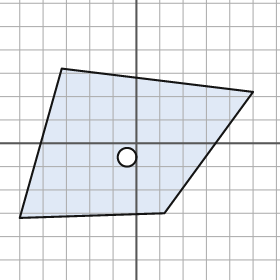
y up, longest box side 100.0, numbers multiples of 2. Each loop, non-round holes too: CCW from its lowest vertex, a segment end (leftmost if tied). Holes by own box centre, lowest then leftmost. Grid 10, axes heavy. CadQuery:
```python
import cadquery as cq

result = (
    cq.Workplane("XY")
    .moveTo(-50.0, -32.0)
    .lineTo(12.0, -30.0)
    .lineTo(50.0, 22.0)
    .lineTo(-32.0, 32.0)
    .close()
    .moveTo(-4.0, -6.0)
    .circle(4.0)
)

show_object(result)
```